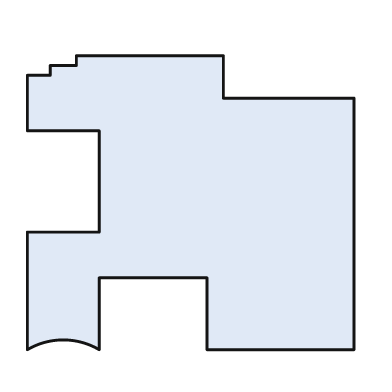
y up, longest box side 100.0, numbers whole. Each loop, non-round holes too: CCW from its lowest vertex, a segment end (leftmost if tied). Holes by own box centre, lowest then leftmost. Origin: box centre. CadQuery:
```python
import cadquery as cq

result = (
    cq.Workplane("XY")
    .moveTo(-50.0, -45.0)
    .threePointArc((-39.0, -42.0), (-28.0, -45.0))
    .lineTo(-28.0, -23.0)
    .lineTo(5.0, -23.0)
    .lineTo(5.0, -45.0)
    .lineTo(50.0, -45.0)
    .lineTo(50.0, 32.0)
    .lineTo(10.0, 32.0)
    .lineTo(10.0, 45.0)
    .lineTo(-35.0, 45.0)
    .lineTo(-35.0, 42.0)
    .lineTo(-43.0, 42.0)
    .lineTo(-43.0, 39.0)
    .lineTo(-50.0, 39.0)
    .lineTo(-50.0, 22.0)
    .lineTo(-28.0, 22.0)
    .lineTo(-28.0, -9.0)
    .lineTo(-50.0, -9.0)
    .close()
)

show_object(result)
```